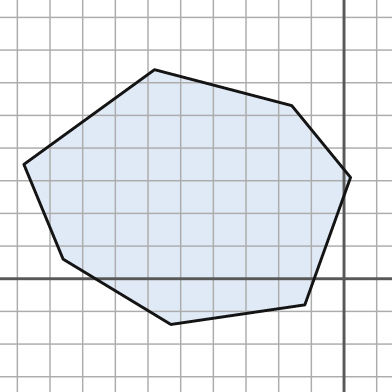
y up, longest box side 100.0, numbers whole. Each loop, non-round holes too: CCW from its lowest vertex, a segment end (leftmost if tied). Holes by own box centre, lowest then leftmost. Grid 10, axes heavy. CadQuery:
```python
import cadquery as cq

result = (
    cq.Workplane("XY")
    .moveTo(-53.0, -14.0)
    .lineTo(-12.0, -8.0)
    .lineTo(2.0, 31.0)
    .lineTo(-16.0, 53.0)
    .lineTo(-58.0, 64.0)
    .lineTo(-98.0, 35.0)
    .lineTo(-86.0, 6.0)
    .close()
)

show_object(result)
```